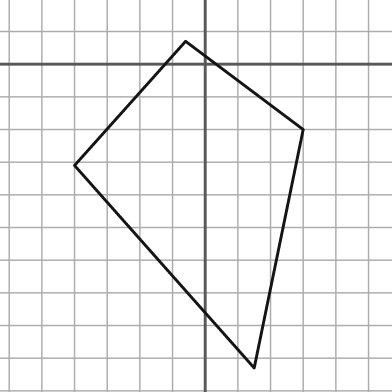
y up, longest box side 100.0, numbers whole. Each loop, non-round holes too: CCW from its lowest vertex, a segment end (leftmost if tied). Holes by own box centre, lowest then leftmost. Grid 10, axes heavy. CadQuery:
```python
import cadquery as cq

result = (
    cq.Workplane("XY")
    .moveTo(15.0, -93.0)
    .lineTo(30.0, -20.0)
    .lineTo(-6.0, 7.0)
    .lineTo(-40.0, -31.0)
    .close()
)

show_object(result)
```